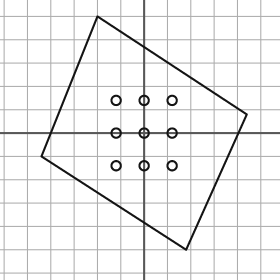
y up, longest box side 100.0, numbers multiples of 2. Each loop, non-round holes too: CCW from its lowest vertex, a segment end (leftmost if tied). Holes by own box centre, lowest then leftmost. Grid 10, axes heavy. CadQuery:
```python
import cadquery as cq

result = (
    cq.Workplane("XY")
    .moveTo(18.0, -50.0)
    .lineTo(44.0, 8.0)
    .lineTo(-20.0, 50.0)
    .lineTo(-44.0, -10.0)
    .close()
    .moveTo(-12.0, -14.0)
    .circle(2.0)
    .moveTo(0.0, -14.0)
    .circle(2.0)
    .moveTo(12.0, -14.0)
    .circle(2.0)
    .moveTo(-12.0, 0.0)
    .circle(2.0)
    .moveTo(0.0, 0.0)
    .circle(2.0)
    .moveTo(12.0, 0.0)
    .circle(2.0)
    .moveTo(-12.0, 14.0)
    .circle(2.0)
    .moveTo(0.0, 14.0)
    .circle(2.0)
    .moveTo(12.0, 14.0)
    .circle(2.0)
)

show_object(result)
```